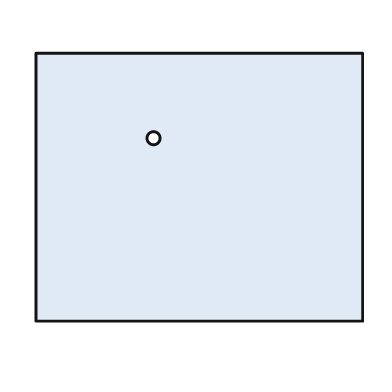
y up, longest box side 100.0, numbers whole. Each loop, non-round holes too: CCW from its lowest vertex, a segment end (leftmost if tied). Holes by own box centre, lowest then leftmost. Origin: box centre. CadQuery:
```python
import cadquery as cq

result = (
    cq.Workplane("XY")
    .moveTo(-50.0, -41.0)
    .lineTo(50.0, -41.0)
    .lineTo(50.0, 41.0)
    .lineTo(-50.0, 41.0)
    .close()
    .moveTo(-14.0, 15.0)
    .circle(2.0)
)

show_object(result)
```